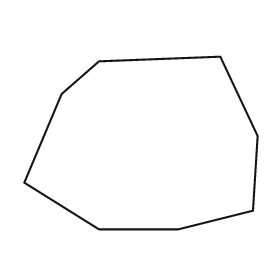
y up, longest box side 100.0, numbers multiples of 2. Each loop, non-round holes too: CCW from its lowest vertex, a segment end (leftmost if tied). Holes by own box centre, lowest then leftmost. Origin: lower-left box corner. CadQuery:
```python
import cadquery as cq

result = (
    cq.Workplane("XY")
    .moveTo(32.0, 0.0)
    .lineTo(66.0, 0.0)
    .lineTo(98.0, 8.0)
    .lineTo(100.0, 40.0)
    .lineTo(84.0, 74.0)
    .lineTo(32.0, 72.0)
    .lineTo(16.0, 58.0)
    .lineTo(0.0, 20.0)
    .close()
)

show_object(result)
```